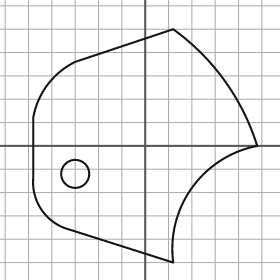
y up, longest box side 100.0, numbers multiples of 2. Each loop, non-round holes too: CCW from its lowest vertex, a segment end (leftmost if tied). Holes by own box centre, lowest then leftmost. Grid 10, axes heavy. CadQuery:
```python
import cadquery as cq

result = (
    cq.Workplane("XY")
    .moveTo(12.0, -50.0)
    .threePointArc((20.0, -18.0), (48.0, 0.0))
    .threePointArc((34.0, 28.0), (12.0, 50.0))
    .lineTo(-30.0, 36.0)
    .threePointArc((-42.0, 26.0), (-48.0, 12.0))
    .lineTo(-48.0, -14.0)
    .threePointArc((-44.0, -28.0), (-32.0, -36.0))
    .close()
    .moveTo(-30.0, -12.0)
    .circle(6.0)
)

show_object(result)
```